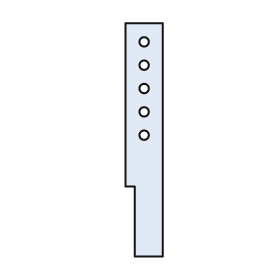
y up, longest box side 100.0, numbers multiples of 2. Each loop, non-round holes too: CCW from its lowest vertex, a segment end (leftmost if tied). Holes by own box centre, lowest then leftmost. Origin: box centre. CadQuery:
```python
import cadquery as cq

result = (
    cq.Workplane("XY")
    .moveTo(-4.0, -50.0)
    .lineTo(8.0, -50.0)
    .lineTo(8.0, 50.0)
    .lineTo(-8.0, 50.0)
    .lineTo(-8.0, -20.0)
    .lineTo(-4.0, -20.0)
    .close()
    .moveTo(0.0, 2.0)
    .circle(2.0)
    .moveTo(0.0, 12.0)
    .circle(2.0)
    .moveTo(0.0, 22.0)
    .circle(2.0)
    .moveTo(0.0, 32.0)
    .circle(2.0)
    .moveTo(0.0, 42.0)
    .circle(2.0)
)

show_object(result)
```